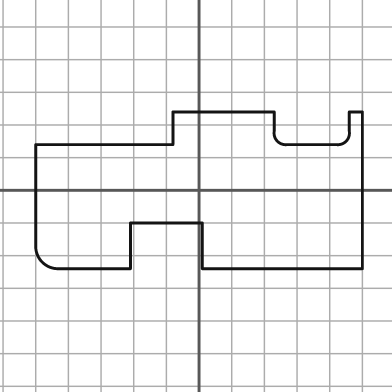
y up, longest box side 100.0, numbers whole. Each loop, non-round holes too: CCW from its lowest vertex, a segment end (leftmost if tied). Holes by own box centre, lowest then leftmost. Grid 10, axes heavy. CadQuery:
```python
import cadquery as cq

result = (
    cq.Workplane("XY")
    .moveTo(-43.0, -24.0)
    .lineTo(-21.0, -24.0)
    .lineTo(-21.0, -10.0)
    .lineTo(1.0, -10.0)
    .lineTo(1.0, -24.0)
    .lineTo(50.0, -24.0)
    .lineTo(50.0, 24.0)
    .lineTo(46.0, 24.0)
    .lineTo(46.0, 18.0)
    .threePointArc((45.0, 15.0), (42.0, 14.0))
    .lineTo(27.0, 14.0)
    .threePointArc((24.0, 15.0), (23.0, 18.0))
    .lineTo(23.0, 24.0)
    .lineTo(-8.0, 24.0)
    .lineTo(-8.0, 14.0)
    .lineTo(-50.0, 14.0)
    .lineTo(-50.0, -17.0)
    .threePointArc((-48.0, -22.0), (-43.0, -24.0))
    .close()
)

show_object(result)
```